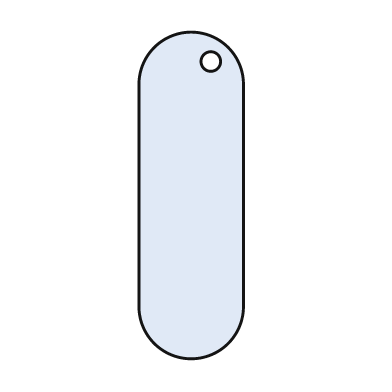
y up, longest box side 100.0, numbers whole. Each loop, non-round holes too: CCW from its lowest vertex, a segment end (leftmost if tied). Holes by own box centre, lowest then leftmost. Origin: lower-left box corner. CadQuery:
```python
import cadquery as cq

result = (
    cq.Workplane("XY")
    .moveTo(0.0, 16.0)
    .threePointArc((16.0, 0.0), (32.0, 16.0))
    .lineTo(32.0, 84.0)
    .threePointArc((16.0, 100.0), (0.0, 84.0))
    .close()
    .moveTo(22.0, 91.0)
    .circle(3.0)
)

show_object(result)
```